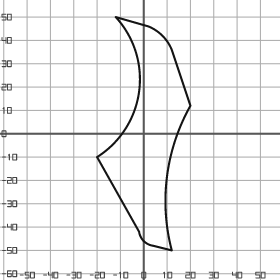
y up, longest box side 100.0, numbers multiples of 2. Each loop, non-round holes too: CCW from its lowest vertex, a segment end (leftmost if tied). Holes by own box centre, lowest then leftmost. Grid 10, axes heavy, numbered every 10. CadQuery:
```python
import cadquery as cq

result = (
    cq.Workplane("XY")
    .moveTo(12.0, -50.0)
    .threePointArc((10.0, -18.0), (20.0, 12.0))
    .lineTo(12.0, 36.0)
    .threePointArc((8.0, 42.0), (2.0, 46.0))
    .lineTo(-12.0, 50.0)
    .threePointArc((-2.0, 18.0), (-20.0, -10.0))
    .lineTo(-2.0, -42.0)
    .threePointArc((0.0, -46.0), (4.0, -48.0))
    .close()
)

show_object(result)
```